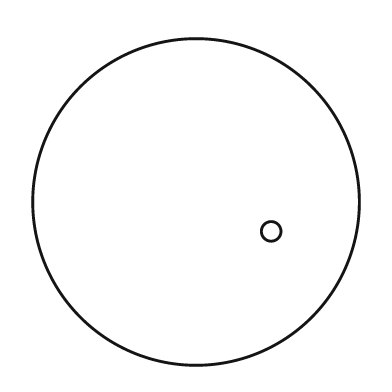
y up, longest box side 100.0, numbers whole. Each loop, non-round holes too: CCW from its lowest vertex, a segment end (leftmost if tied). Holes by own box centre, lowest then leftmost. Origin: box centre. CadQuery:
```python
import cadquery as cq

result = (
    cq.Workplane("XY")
    .moveTo(0.0, 0.0)
    .circle(50.0)
    .moveTo(23.0, -9.0)
    .circle(3.0)
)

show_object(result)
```